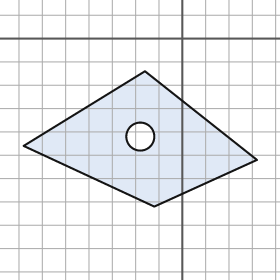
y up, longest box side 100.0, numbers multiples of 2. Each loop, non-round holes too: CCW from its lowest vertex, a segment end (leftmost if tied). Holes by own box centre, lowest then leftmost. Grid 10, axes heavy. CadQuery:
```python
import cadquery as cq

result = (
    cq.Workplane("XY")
    .moveTo(-12.0, -72.0)
    .lineTo(32.0, -52.0)
    .lineTo(-16.0, -14.0)
    .lineTo(-68.0, -46.0)
    .close()
    .moveTo(-18.0, -42.0)
    .circle(6.0)
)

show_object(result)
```